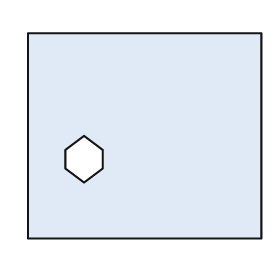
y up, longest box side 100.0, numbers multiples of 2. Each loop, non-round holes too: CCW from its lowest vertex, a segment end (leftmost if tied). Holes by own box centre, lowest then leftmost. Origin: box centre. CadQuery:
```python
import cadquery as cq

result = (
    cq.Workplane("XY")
    .moveTo(-50.0, -44.0)
    .lineTo(50.0, -44.0)
    .lineTo(50.0, 44.0)
    .lineTo(-50.0, 44.0)
    .close()
    .moveTo(-26.0, -20.0)
    .lineTo(-18.0, -14.0)
    .lineTo(-18.0, -6.0)
    .lineTo(-26.0, 0.0)
    .lineTo(-34.0, -6.0)
    .lineTo(-34.0, -14.0)
    .close()
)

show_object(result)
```